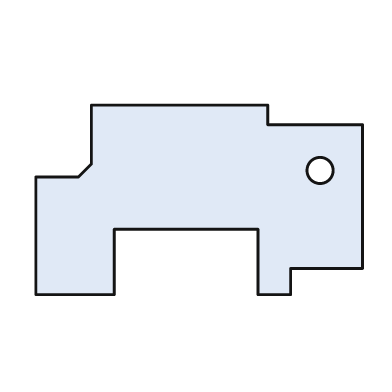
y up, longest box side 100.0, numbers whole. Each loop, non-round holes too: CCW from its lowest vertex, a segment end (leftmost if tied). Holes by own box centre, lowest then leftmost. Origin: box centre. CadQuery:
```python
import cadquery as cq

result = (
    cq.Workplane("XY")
    .moveTo(-50.0, -29.0)
    .lineTo(-26.0, -29.0)
    .lineTo(-26.0, -9.0)
    .lineTo(18.0, -9.0)
    .lineTo(18.0, -29.0)
    .lineTo(28.0, -29.0)
    .lineTo(28.0, -21.0)
    .lineTo(50.0, -21.0)
    .lineTo(50.0, 23.0)
    .lineTo(21.0, 23.0)
    .lineTo(21.0, 29.0)
    .lineTo(-33.0, 29.0)
    .lineTo(-33.0, 11.0)
    .lineTo(-37.0, 7.0)
    .lineTo(-50.0, 7.0)
    .close()
    .moveTo(37.0, 9.0)
    .circle(4.0)
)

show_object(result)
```